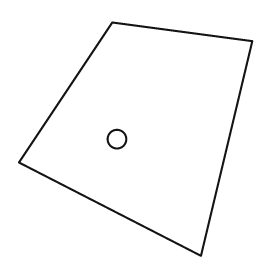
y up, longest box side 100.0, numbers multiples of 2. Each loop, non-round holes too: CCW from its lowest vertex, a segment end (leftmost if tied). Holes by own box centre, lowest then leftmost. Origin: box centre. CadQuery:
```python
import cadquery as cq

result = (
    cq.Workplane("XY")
    .moveTo(28.0, -50.0)
    .lineTo(50.0, 42.0)
    .lineTo(-10.0, 50.0)
    .lineTo(-50.0, -10.0)
    .close()
    .moveTo(-8.0, 0.0)
    .circle(4.0)
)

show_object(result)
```